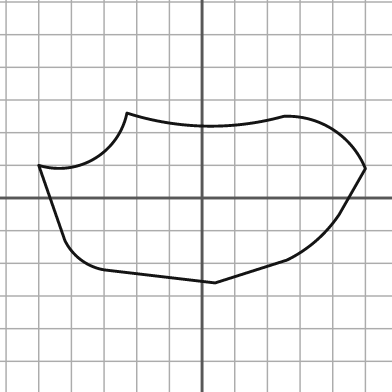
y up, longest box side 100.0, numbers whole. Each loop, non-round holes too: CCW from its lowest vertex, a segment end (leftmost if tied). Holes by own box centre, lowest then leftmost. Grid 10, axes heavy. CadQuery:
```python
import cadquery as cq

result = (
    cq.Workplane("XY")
    .moveTo(4.0, -26.0)
    .lineTo(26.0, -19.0)
    .threePointArc((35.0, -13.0), (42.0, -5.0))
    .lineTo(50.0, 9.0)
    .threePointArc((40.0, 21.0), (25.0, 25.0))
    .threePointArc((1.0, 22.0), (-23.0, 26.0))
    .threePointArc((-33.0, 12.0), (-50.0, 10.0))
    .lineTo(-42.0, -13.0)
    .threePointArc((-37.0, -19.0), (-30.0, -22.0))
    .close()
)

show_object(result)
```